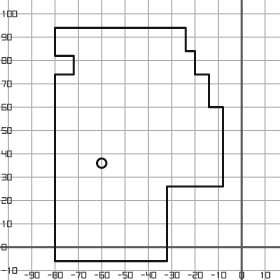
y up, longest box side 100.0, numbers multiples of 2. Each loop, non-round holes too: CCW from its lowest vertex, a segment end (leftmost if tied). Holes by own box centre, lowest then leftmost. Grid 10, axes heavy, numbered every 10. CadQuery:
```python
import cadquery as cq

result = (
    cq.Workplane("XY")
    .moveTo(-80.0, -6.0)
    .lineTo(-32.0, -6.0)
    .lineTo(-32.0, 26.0)
    .lineTo(-8.0, 26.0)
    .lineTo(-8.0, 60.0)
    .lineTo(-14.0, 60.0)
    .lineTo(-14.0, 74.0)
    .lineTo(-20.0, 74.0)
    .lineTo(-20.0, 84.0)
    .lineTo(-24.0, 84.0)
    .lineTo(-24.0, 94.0)
    .lineTo(-80.0, 94.0)
    .lineTo(-80.0, 82.0)
    .lineTo(-72.0, 82.0)
    .lineTo(-72.0, 74.0)
    .lineTo(-80.0, 74.0)
    .close()
    .moveTo(-60.0, 36.0)
    .circle(2.0)
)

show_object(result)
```